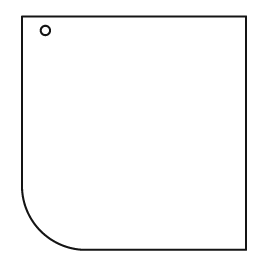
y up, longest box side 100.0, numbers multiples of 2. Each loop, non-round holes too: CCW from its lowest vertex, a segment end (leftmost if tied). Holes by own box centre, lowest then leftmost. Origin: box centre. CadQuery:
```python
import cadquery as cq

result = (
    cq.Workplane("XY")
    .moveTo(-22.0, -50.0)
    .lineTo(48.0, -50.0)
    .lineTo(48.0, 50.0)
    .lineTo(-48.0, 50.0)
    .lineTo(-48.0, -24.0)
    .threePointArc((-40.0, -42.0), (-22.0, -50.0))
    .close()
    .moveTo(-38.0, 44.0)
    .circle(2.0)
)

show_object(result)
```